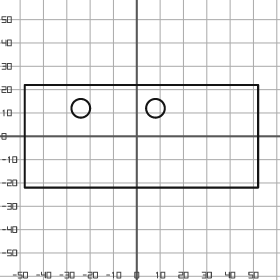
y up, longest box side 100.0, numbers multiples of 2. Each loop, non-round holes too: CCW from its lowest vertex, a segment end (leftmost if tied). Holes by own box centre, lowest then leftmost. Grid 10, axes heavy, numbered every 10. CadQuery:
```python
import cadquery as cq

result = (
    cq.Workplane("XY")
    .moveTo(-48.0, -22.0)
    .lineTo(52.0, -22.0)
    .lineTo(52.0, 22.0)
    .lineTo(-48.0, 22.0)
    .close()
    .moveTo(-24.0, 12.0)
    .circle(4.0)
    .moveTo(8.0, 12.0)
    .circle(4.0)
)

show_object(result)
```